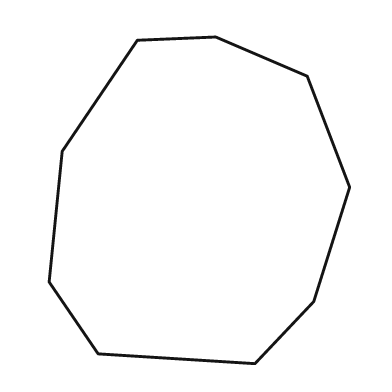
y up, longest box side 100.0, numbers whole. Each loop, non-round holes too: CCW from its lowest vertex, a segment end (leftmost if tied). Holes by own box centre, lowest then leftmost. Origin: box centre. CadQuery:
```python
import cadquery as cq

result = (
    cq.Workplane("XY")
    .moveTo(17.0, -50.0)
    .lineTo(35.0, -31.0)
    .lineTo(46.0, 4.0)
    .lineTo(33.0, 38.0)
    .lineTo(5.0, 50.0)
    .lineTo(-19.0, 49.0)
    .lineTo(-42.0, 15.0)
    .lineTo(-46.0, -25.0)
    .lineTo(-31.0, -47.0)
    .close()
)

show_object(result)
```